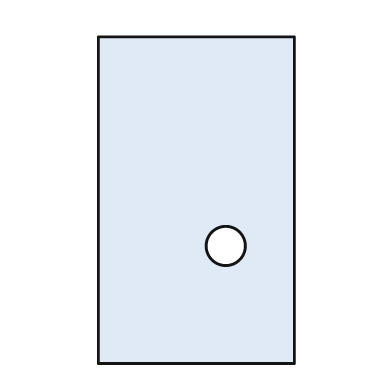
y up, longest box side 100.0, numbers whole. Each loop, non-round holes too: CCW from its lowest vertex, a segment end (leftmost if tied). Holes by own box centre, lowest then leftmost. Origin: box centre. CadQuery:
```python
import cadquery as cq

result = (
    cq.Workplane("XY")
    .moveTo(-30.0, -50.0)
    .lineTo(30.0, -50.0)
    .lineTo(30.0, 50.0)
    .lineTo(-30.0, 50.0)
    .close()
    .moveTo(9.0, -14.0)
    .circle(6.0)
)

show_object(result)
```